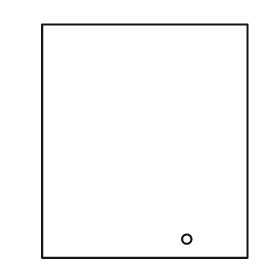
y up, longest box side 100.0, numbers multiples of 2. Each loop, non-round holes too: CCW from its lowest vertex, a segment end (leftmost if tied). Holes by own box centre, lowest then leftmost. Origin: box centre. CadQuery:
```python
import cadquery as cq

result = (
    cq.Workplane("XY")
    .moveTo(-44.0, -50.0)
    .lineTo(44.0, -50.0)
    .lineTo(44.0, 50.0)
    .lineTo(-44.0, 50.0)
    .close()
    .moveTo(18.0, -42.0)
    .circle(2.0)
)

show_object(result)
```